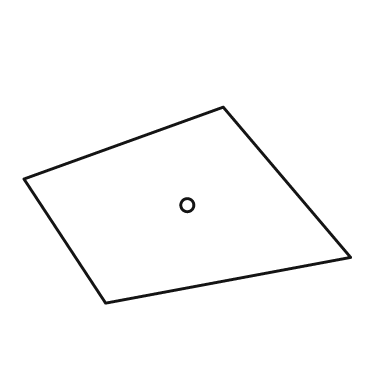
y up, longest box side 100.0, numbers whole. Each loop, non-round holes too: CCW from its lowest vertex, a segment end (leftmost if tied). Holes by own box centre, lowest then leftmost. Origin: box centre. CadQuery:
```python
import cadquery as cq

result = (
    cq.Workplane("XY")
    .moveTo(-25.0, -30.0)
    .lineTo(50.0, -16.0)
    .lineTo(11.0, 30.0)
    .lineTo(-50.0, 8.0)
    .close()
    .moveTo(0.0, 0.0)
    .circle(2.0)
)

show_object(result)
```